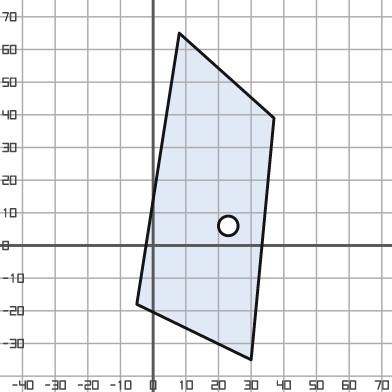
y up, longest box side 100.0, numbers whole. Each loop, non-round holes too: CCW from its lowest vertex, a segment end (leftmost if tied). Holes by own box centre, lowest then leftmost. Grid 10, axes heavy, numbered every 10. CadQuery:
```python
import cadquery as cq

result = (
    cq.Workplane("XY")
    .moveTo(30.0, -35.0)
    .lineTo(37.0, 39.0)
    .lineTo(8.0, 65.0)
    .lineTo(-5.0, -18.0)
    .close()
    .moveTo(23.0, 6.0)
    .circle(3.0)
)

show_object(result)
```